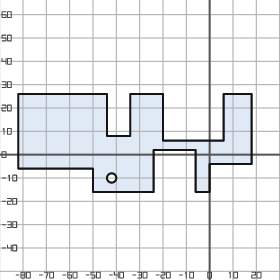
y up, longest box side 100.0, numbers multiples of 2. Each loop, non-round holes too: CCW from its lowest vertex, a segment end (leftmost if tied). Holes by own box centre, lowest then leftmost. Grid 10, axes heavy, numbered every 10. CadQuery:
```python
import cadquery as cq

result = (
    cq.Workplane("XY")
    .moveTo(-50.0, -16.0)
    .lineTo(-24.0, -16.0)
    .lineTo(-24.0, 2.0)
    .lineTo(-6.0, 2.0)
    .lineTo(-6.0, -16.0)
    .lineTo(0.0, -16.0)
    .lineTo(0.0, -4.0)
    .lineTo(18.0, -4.0)
    .lineTo(18.0, 26.0)
    .lineTo(6.0, 26.0)
    .lineTo(6.0, 6.0)
    .lineTo(-20.0, 6.0)
    .lineTo(-20.0, 26.0)
    .lineTo(-34.0, 26.0)
    .lineTo(-34.0, 8.0)
    .lineTo(-44.0, 8.0)
    .lineTo(-44.0, 26.0)
    .lineTo(-82.0, 26.0)
    .lineTo(-82.0, -6.0)
    .lineTo(-50.0, -6.0)
    .close()
    .moveTo(-42.0, -10.0)
    .circle(2.0)
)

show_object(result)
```